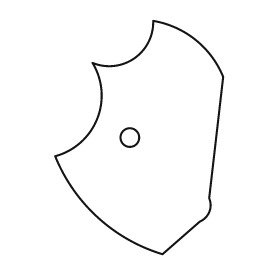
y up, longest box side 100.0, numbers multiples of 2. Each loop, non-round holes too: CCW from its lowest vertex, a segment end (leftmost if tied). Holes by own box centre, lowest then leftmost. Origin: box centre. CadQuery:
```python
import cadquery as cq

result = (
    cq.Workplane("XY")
    .moveTo(10.0, -50.0)
    .lineTo(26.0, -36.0)
    .threePointArc((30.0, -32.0), (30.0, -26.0))
    .lineTo(36.0, 26.0)
    .threePointArc((24.0, 42.0), (6.0, 50.0))
    .threePointArc((-2.0, 34.0), (-20.0, 32.0))
    .threePointArc((-18.0, 8.0), (-36.0, -8.0))
    .threePointArc((-18.0, -34.0), (10.0, -50.0))
    .close()
    .moveTo(-4.0, 0.0)
    .circle(4.0)
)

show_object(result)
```